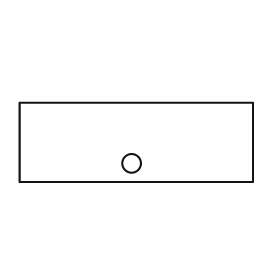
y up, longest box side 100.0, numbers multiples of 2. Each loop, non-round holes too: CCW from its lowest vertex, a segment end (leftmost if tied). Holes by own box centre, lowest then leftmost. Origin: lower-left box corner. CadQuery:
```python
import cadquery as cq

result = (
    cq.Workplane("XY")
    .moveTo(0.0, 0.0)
    .lineTo(100.0, 0.0)
    .lineTo(100.0, 34.0)
    .lineTo(0.0, 34.0)
    .close()
    .moveTo(48.0, 8.0)
    .circle(4.0)
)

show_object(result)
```